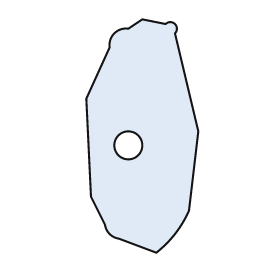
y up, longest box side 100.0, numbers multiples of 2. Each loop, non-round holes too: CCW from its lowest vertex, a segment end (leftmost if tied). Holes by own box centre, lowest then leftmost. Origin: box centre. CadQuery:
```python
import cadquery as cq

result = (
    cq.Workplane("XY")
    .moveTo(6.0, -50.0)
    .threePointArc((14.0, -42.0), (20.0, -32.0))
    .lineTo(24.0, 2.0)
    .lineTo(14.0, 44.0)
    .threePointArc((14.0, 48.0), (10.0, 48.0))
    .lineTo(0.0, 50.0)
    .lineTo(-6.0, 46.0)
    .threePointArc((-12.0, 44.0), (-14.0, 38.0))
    .lineTo(-24.0, 16.0)
    .lineTo(-22.0, -26.0)
    .lineTo(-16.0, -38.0)
    .threePointArc((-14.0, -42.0), (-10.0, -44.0))
    .close()
    .moveTo(-6.0, -4.0)
    .circle(6.0)
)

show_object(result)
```